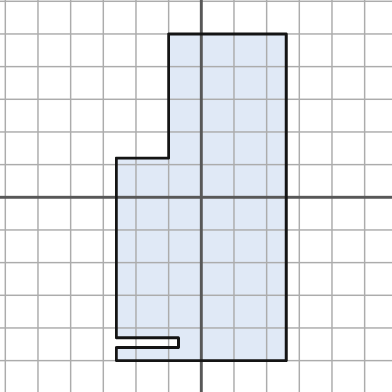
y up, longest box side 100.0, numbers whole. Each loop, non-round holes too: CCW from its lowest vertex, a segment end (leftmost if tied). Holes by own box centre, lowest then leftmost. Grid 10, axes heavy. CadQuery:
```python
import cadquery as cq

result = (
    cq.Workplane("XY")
    .moveTo(-26.0, -50.0)
    .lineTo(26.0, -50.0)
    .lineTo(26.0, 50.0)
    .lineTo(-10.0, 50.0)
    .lineTo(-10.0, 12.0)
    .lineTo(-26.0, 12.0)
    .lineTo(-26.0, -43.0)
    .lineTo(-7.0, -43.0)
    .lineTo(-7.0, -46.0)
    .lineTo(-26.0, -46.0)
    .close()
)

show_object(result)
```